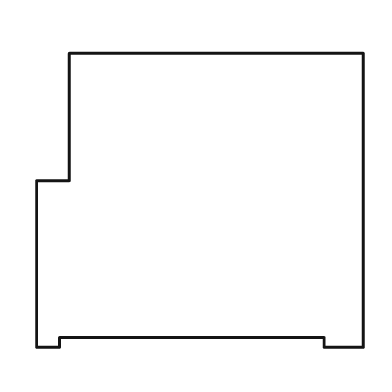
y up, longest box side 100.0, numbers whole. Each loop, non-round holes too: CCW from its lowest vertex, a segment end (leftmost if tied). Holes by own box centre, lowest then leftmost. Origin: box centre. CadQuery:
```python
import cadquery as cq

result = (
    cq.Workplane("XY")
    .moveTo(-50.0, -45.0)
    .lineTo(-43.0, -45.0)
    .lineTo(-43.0, -42.0)
    .lineTo(38.0, -42.0)
    .lineTo(38.0, -45.0)
    .lineTo(50.0, -45.0)
    .lineTo(50.0, 45.0)
    .lineTo(-40.0, 45.0)
    .lineTo(-40.0, 6.0)
    .lineTo(-50.0, 6.0)
    .close()
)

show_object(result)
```